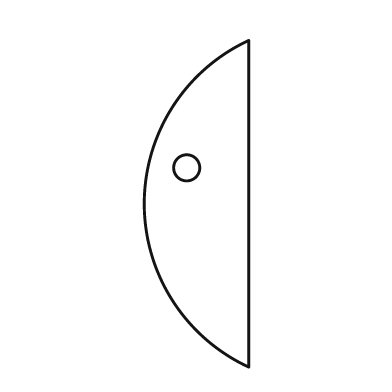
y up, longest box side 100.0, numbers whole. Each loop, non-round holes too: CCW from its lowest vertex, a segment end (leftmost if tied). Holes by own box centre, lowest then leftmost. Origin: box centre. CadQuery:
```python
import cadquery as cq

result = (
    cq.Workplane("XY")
    .moveTo(16.0, -50.0)
    .lineTo(16.0, 50.0)
    .threePointArc((-16.0, 0.0), (16.0, -50.0))
    .close()
    .moveTo(-3.0, 11.0)
    .circle(4.0)
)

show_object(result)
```